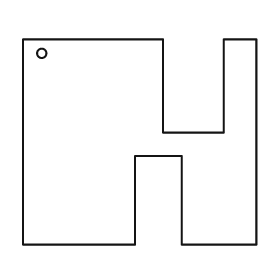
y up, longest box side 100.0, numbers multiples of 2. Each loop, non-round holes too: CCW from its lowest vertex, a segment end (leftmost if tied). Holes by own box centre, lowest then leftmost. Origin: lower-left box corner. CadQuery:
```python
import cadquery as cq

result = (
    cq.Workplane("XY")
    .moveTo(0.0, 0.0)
    .lineTo(48.0, 0.0)
    .lineTo(48.0, 38.0)
    .lineTo(68.0, 38.0)
    .lineTo(68.0, 0.0)
    .lineTo(100.0, 0.0)
    .lineTo(100.0, 88.0)
    .lineTo(86.0, 88.0)
    .lineTo(86.0, 48.0)
    .lineTo(60.0, 48.0)
    .lineTo(60.0, 88.0)
    .lineTo(0.0, 88.0)
    .close()
    .moveTo(8.0, 82.0)
    .circle(2.0)
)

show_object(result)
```